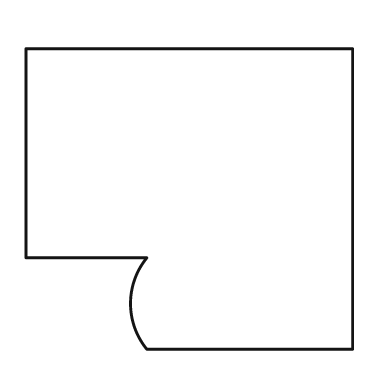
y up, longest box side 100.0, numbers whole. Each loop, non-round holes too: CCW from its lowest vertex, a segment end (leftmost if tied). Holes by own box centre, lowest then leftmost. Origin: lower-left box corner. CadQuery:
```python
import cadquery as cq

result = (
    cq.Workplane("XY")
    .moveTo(37.0, 0.0)
    .lineTo(100.0, 0.0)
    .lineTo(100.0, 92.0)
    .lineTo(0.0, 92.0)
    .lineTo(0.0, 28.0)
    .lineTo(37.0, 28.0)
    .threePointArc((32.0, 14.0), (37.0, 0.0))
    .close()
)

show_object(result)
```